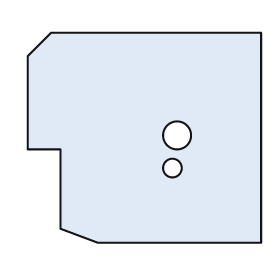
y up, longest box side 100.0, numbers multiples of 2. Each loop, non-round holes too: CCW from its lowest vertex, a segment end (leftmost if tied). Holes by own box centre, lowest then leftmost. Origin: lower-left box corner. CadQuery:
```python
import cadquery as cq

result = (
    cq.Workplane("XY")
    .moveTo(30.0, 0.0)
    .lineTo(100.0, 0.0)
    .lineTo(100.0, 90.0)
    .lineTo(10.0, 90.0)
    .lineTo(0.0, 80.0)
    .lineTo(0.0, 40.0)
    .lineTo(14.0, 40.0)
    .lineTo(14.0, 6.0)
    .close()
    .moveTo(62.0, 32.0)
    .circle(4.0)
    .moveTo(64.0, 46.0)
    .circle(6.0)
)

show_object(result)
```